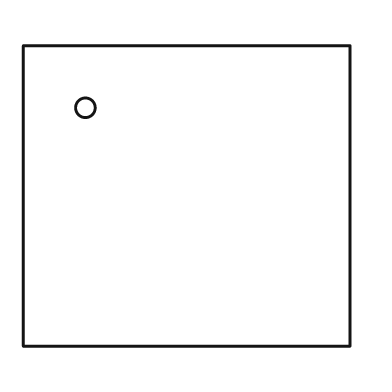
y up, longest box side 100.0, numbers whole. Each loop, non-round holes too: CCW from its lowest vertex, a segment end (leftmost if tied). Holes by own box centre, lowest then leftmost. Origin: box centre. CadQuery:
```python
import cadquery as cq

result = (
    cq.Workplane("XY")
    .moveTo(-50.0, -46.0)
    .lineTo(50.0, -46.0)
    .lineTo(50.0, 46.0)
    .lineTo(-50.0, 46.0)
    .close()
    .moveTo(-31.0, 27.0)
    .circle(3.0)
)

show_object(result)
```